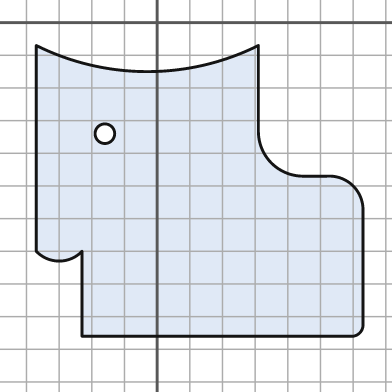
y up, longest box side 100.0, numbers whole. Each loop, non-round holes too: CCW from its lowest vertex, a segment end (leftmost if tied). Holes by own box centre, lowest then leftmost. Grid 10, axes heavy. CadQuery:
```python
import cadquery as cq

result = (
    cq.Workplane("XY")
    .moveTo(-23.0, -96.0)
    .lineTo(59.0, -96.0)
    .threePointArc((62.0, -95.0), (63.0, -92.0))
    .lineTo(63.0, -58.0)
    .threePointArc((60.0, -50.0), (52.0, -47.0))
    .lineTo(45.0, -47.0)
    .threePointArc((35.0, -43.0), (31.0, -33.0))
    .lineTo(31.0, -7.0)
    .threePointArc((-3.0, -15.0), (-37.0, -7.0))
    .lineTo(-37.0, -70.0)
    .threePointArc((-30.0, -73.0), (-23.0, -70.0))
    .close()
    .moveTo(-16.0, -34.0)
    .circle(3.0)
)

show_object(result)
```